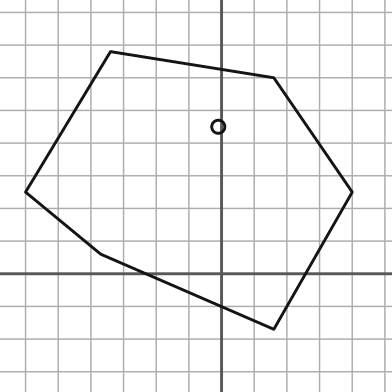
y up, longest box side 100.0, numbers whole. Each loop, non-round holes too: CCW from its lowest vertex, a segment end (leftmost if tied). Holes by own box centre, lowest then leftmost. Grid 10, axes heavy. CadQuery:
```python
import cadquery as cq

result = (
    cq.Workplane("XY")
    .moveTo(16.0, -17.0)
    .lineTo(40.0, 25.0)
    .lineTo(16.0, 60.0)
    .lineTo(-34.0, 68.0)
    .lineTo(-60.0, 25.0)
    .lineTo(-37.0, 6.0)
    .close()
    .moveTo(-1.0, 45.0)
    .circle(2.0)
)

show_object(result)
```